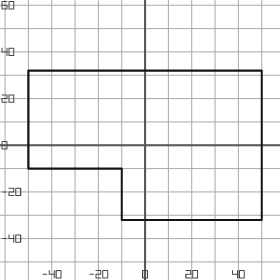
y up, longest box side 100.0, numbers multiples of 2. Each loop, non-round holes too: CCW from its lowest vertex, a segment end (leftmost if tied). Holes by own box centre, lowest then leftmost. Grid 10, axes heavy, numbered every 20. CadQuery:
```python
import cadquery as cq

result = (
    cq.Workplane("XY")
    .moveTo(-10.0, -32.0)
    .lineTo(50.0, -32.0)
    .lineTo(50.0, 32.0)
    .lineTo(-50.0, 32.0)
    .lineTo(-50.0, -10.0)
    .lineTo(-10.0, -10.0)
    .close()
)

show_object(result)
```